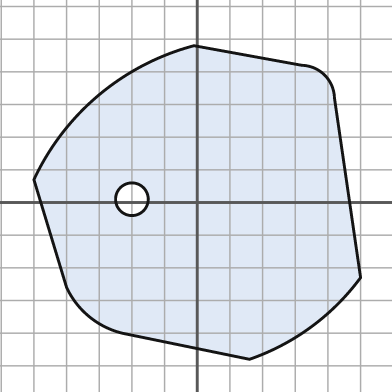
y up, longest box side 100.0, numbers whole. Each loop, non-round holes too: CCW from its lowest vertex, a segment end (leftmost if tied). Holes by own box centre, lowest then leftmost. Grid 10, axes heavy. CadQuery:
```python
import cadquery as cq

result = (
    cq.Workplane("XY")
    .moveTo(16.0, -48.0)
    .threePointArc((35.0, -38.0), (50.0, -23.0))
    .lineTo(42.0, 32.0)
    .threePointArc((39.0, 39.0), (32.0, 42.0))
    .lineTo(-1.0, 48.0)
    .threePointArc((-30.0, 33.0), (-50.0, 7.0))
    .lineTo(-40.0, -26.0)
    .threePointArc((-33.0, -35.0), (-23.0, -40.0))
    .close()
    .moveTo(-20.0, 1.0)
    .circle(5.0)
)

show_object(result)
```